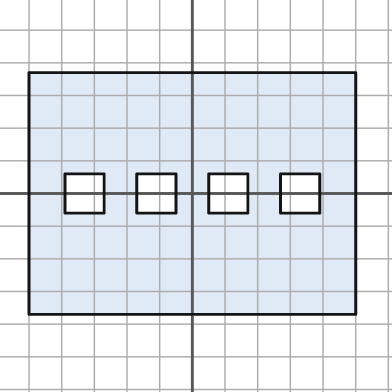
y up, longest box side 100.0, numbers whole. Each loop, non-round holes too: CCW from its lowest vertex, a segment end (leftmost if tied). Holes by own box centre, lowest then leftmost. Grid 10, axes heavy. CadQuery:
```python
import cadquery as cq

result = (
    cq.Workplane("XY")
    .moveTo(-50.0, -37.0)
    .lineTo(50.0, -37.0)
    .lineTo(50.0, 37.0)
    .lineTo(-50.0, 37.0)
    .close()
    .moveTo(-39.0, -6.0)
    .lineTo(-27.0, -6.0)
    .lineTo(-27.0, 6.0)
    .lineTo(-39.0, 6.0)
    .close()
    .moveTo(-17.0, -6.0)
    .lineTo(-5.0, -6.0)
    .lineTo(-5.0, 6.0)
    .lineTo(-17.0, 6.0)
    .close()
    .moveTo(5.0, -6.0)
    .lineTo(17.0, -6.0)
    .lineTo(17.0, 6.0)
    .lineTo(5.0, 6.0)
    .close()
    .moveTo(27.0, -6.0)
    .lineTo(39.0, -6.0)
    .lineTo(39.0, 6.0)
    .lineTo(27.0, 6.0)
    .close()
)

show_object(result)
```